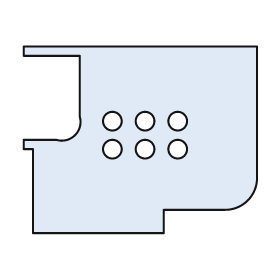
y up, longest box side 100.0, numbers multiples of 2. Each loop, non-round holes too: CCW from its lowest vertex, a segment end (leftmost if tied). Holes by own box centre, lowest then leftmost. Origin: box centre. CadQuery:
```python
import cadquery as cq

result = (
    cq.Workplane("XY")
    .moveTo(-46.0, -40.0)
    .lineTo(10.0, -40.0)
    .lineTo(10.0, -30.0)
    .lineTo(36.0, -30.0)
    .threePointArc((46.0, -26.0), (50.0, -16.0))
    .lineTo(50.0, 40.0)
    .lineTo(-50.0, 40.0)
    .lineTo(-50.0, 36.0)
    .lineTo(-26.0, 36.0)
    .lineTo(-26.0, 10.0)
    .threePointArc((-28.0, 2.0), (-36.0, 0.0))
    .lineTo(-50.0, 0.0)
    .lineTo(-50.0, -4.0)
    .lineTo(-46.0, -4.0)
    .close()
    .moveTo(-12.0, -4.0)
    .circle(4.0)
    .moveTo(2.0, -4.0)
    .circle(4.0)
    .moveTo(16.0, -4.0)
    .circle(4.0)
    .moveTo(-12.0, 8.0)
    .circle(4.0)
    .moveTo(2.0, 8.0)
    .circle(4.0)
    .moveTo(16.0, 8.0)
    .circle(4.0)
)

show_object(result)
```